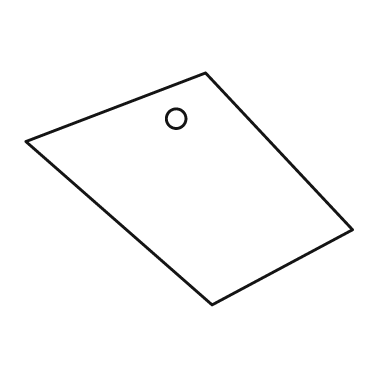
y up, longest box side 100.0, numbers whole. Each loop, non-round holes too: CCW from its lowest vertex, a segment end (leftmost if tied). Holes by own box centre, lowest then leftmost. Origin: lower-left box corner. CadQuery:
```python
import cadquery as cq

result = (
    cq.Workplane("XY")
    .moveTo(57.0, 0.0)
    .lineTo(100.0, 23.0)
    .lineTo(55.0, 71.0)
    .lineTo(0.0, 50.0)
    .close()
    .moveTo(46.0, 57.0)
    .circle(3.0)
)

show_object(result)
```